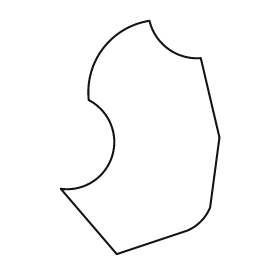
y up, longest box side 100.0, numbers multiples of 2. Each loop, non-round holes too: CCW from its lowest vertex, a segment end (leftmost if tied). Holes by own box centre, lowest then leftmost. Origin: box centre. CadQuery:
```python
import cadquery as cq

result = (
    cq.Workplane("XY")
    .moveTo(-10.0, -50.0)
    .lineTo(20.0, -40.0)
    .threePointArc((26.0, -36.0), (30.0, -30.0))
    .lineTo(34.0, 0.0)
    .lineTo(26.0, 34.0)
    .threePointArc((12.0, 38.0), (4.0, 50.0))
    .threePointArc((-16.0, 38.0), (-22.0, 16.0))
    .threePointArc((-12.0, -8.0), (-34.0, -22.0))
    .close()
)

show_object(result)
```